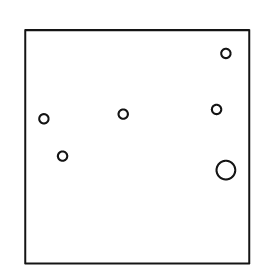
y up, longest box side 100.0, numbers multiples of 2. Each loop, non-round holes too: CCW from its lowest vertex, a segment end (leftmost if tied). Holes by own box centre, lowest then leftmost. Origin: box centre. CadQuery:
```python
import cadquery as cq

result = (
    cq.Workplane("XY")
    .moveTo(-48.0, -50.0)
    .lineTo(48.0, -50.0)
    .lineTo(48.0, 50.0)
    .lineTo(-48.0, 50.0)
    .close()
    .moveTo(38.0, -10.0)
    .circle(4.0)
    .moveTo(-32.0, -4.0)
    .circle(2.0)
    .moveTo(-40.0, 12.0)
    .circle(2.0)
    .moveTo(-6.0, 14.0)
    .circle(2.0)
    .moveTo(34.0, 16.0)
    .circle(2.0)
    .moveTo(38.0, 40.0)
    .circle(2.0)
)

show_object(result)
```